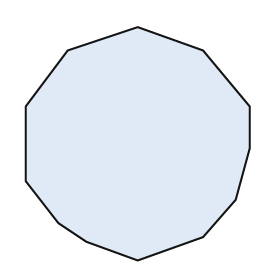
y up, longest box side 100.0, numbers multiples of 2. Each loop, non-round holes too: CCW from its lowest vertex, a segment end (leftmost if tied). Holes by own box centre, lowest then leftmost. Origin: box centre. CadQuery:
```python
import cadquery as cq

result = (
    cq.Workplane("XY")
    .moveTo(0.0, -50.0)
    .lineTo(28.0, -40.0)
    .lineTo(42.0, -24.0)
    .lineTo(48.0, -2.0)
    .lineTo(48.0, 16.0)
    .lineTo(28.0, 40.0)
    .lineTo(0.0, 50.0)
    .lineTo(-30.0, 40.0)
    .lineTo(-48.0, 16.0)
    .lineTo(-48.0, -16.0)
    .lineTo(-34.0, -34.0)
    .lineTo(-22.0, -42.0)
    .close()
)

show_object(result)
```